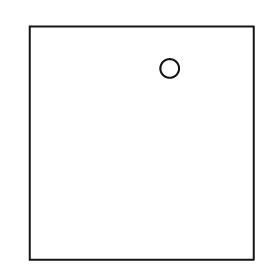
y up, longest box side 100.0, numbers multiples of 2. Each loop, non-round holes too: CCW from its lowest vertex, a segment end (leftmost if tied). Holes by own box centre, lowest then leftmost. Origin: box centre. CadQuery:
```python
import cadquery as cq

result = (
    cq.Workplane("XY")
    .moveTo(-48.0, -50.0)
    .lineTo(48.0, -50.0)
    .lineTo(48.0, 50.0)
    .lineTo(-48.0, 50.0)
    .close()
    .moveTo(12.0, 32.0)
    .circle(4.0)
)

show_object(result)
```